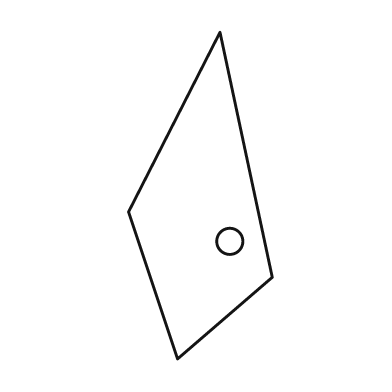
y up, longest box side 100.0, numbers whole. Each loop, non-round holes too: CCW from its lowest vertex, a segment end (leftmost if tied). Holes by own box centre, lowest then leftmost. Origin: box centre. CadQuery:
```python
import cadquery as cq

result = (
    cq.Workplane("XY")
    .moveTo(-7.0, -50.0)
    .lineTo(22.0, -25.0)
    .lineTo(6.0, 50.0)
    .lineTo(-22.0, -5.0)
    .close()
    .moveTo(9.0, -14.0)
    .circle(4.0)
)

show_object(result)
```